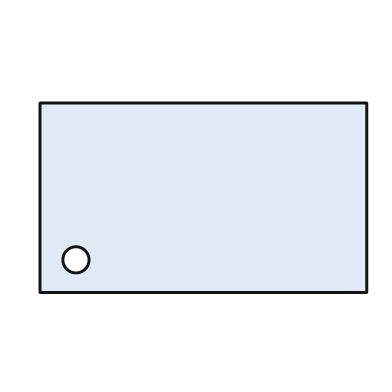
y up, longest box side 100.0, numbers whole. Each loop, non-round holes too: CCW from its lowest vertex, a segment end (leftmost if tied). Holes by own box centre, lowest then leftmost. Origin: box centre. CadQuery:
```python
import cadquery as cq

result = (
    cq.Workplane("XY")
    .moveTo(-50.0, -29.0)
    .lineTo(50.0, -29.0)
    .lineTo(50.0, 29.0)
    .lineTo(-50.0, 29.0)
    .close()
    .moveTo(-39.0, -19.0)
    .circle(4.0)
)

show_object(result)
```